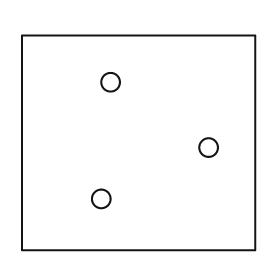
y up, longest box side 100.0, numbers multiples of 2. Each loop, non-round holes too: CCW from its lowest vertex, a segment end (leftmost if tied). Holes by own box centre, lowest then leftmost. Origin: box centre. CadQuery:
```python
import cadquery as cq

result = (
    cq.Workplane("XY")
    .moveTo(-50.0, -46.0)
    .lineTo(50.0, -46.0)
    .lineTo(50.0, 46.0)
    .lineTo(-50.0, 46.0)
    .close()
    .moveTo(-16.0, -24.0)
    .circle(4.0)
    .moveTo(30.0, -2.0)
    .circle(4.0)
    .moveTo(-12.0, 26.0)
    .circle(4.0)
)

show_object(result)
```